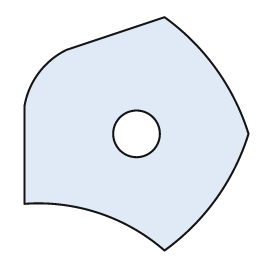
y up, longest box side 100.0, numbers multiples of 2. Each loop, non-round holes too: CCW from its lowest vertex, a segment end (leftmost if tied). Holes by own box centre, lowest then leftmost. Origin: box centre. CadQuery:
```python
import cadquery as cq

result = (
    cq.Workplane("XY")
    .moveTo(12.0, -50.0)
    .threePointArc((34.0, -28.0), (48.0, 0.0))
    .threePointArc((34.0, 28.0), (12.0, 50.0))
    .lineTo(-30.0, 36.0)
    .threePointArc((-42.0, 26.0), (-48.0, 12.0))
    .lineTo(-48.0, -30.0)
    .threePointArc((-16.0, -34.0), (12.0, -50.0))
    .close()
    .moveTo(0.0, 0.0)
    .circle(10.0)
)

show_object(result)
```